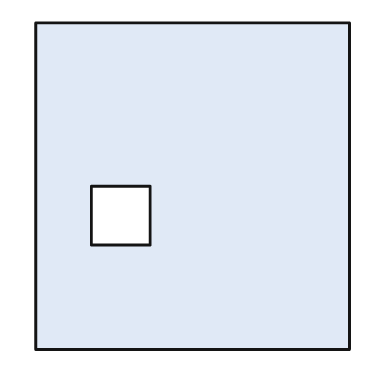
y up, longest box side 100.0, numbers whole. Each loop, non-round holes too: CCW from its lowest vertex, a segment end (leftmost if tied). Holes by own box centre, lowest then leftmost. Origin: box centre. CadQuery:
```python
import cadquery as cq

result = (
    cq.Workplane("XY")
    .moveTo(-48.0, -50.0)
    .lineTo(48.0, -50.0)
    .lineTo(48.0, 50.0)
    .lineTo(-48.0, 50.0)
    .close()
    .moveTo(-31.0, -18.0)
    .lineTo(-13.0, -18.0)
    .lineTo(-13.0, 0.0)
    .lineTo(-31.0, 0.0)
    .close()
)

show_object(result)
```